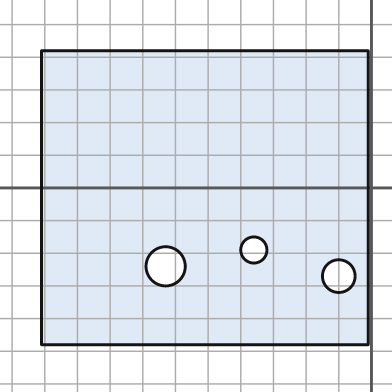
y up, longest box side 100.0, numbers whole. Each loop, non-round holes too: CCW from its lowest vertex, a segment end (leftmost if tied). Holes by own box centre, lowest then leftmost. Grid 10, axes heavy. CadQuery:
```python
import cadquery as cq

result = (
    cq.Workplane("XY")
    .moveTo(-101.0, -48.0)
    .lineTo(-1.0, -48.0)
    .lineTo(-1.0, 42.0)
    .lineTo(-101.0, 42.0)
    .close()
    .moveTo(-10.0, -27.0)
    .circle(5.0)
    .moveTo(-63.0, -24.0)
    .circle(6.0)
    .moveTo(-36.0, -19.0)
    .circle(4.0)
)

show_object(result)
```